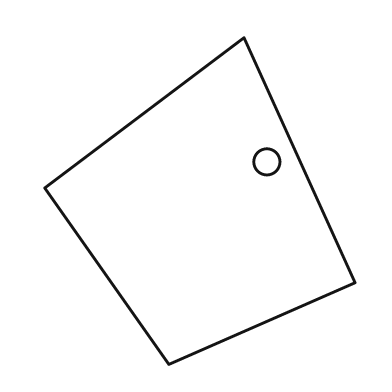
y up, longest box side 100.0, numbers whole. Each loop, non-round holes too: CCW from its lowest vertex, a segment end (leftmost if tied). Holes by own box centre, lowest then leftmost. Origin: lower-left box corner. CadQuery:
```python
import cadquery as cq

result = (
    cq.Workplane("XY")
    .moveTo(38.0, 0.0)
    .lineTo(95.0, 25.0)
    .lineTo(61.0, 100.0)
    .lineTo(0.0, 54.0)
    .close()
    .moveTo(68.0, 62.0)
    .circle(4.0)
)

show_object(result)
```